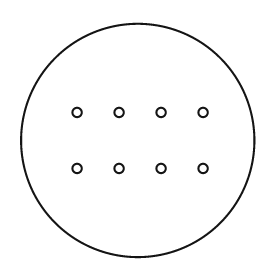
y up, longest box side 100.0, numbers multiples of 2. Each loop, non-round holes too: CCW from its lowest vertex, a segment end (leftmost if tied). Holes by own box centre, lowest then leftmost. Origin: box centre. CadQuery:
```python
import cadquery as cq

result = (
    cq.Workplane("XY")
    .moveTo(0.0, 0.0)
    .circle(50.0)
    .moveTo(-26.0, -12.0)
    .circle(2.0)
    .moveTo(-8.0, -12.0)
    .circle(2.0)
    .moveTo(10.0, -12.0)
    .circle(2.0)
    .moveTo(28.0, -12.0)
    .circle(2.0)
    .moveTo(-26.0, 12.0)
    .circle(2.0)
    .moveTo(-8.0, 12.0)
    .circle(2.0)
    .moveTo(10.0, 12.0)
    .circle(2.0)
    .moveTo(28.0, 12.0)
    .circle(2.0)
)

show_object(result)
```